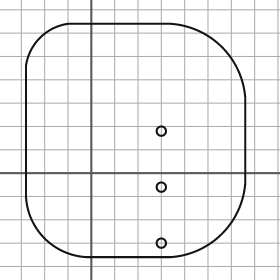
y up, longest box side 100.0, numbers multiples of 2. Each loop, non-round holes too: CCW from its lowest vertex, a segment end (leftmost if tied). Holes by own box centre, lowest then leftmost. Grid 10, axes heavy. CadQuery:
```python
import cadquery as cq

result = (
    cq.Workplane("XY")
    .moveTo(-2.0, -36.0)
    .lineTo(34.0, -36.0)
    .threePointArc((56.0, -26.0), (66.0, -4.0))
    .lineTo(66.0, 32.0)
    .threePointArc((56.0, 54.0), (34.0, 64.0))
    .lineTo(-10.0, 64.0)
    .threePointArc((-22.0, 58.0), (-28.0, 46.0))
    .lineTo(-28.0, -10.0)
    .threePointArc((-20.0, -28.0), (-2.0, -36.0))
    .close()
    .moveTo(30.0, -30.0)
    .circle(2.0)
    .moveTo(30.0, -6.0)
    .circle(2.0)
    .moveTo(30.0, 18.0)
    .circle(2.0)
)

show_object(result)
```